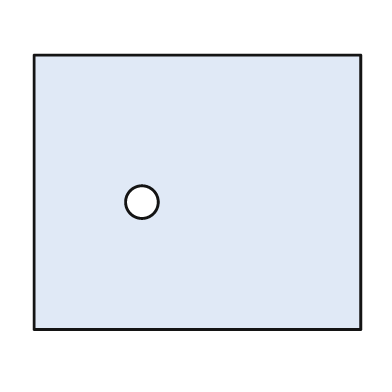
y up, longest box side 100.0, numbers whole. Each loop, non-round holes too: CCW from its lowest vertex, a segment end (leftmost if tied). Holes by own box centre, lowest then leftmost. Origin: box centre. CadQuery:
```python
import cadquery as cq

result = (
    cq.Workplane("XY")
    .moveTo(-50.0, -42.0)
    .lineTo(50.0, -42.0)
    .lineTo(50.0, 42.0)
    .lineTo(-50.0, 42.0)
    .close()
    .moveTo(-17.0, -3.0)
    .circle(5.0)
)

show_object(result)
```